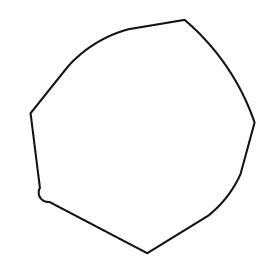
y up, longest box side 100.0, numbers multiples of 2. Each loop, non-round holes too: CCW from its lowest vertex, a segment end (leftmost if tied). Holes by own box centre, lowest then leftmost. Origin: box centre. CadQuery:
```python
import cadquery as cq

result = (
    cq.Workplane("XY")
    .moveTo(2.0, -50.0)
    .lineTo(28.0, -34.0)
    .threePointArc((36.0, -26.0), (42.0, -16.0))
    .lineTo(48.0, 6.0)
    .threePointArc((36.0, 30.0), (18.0, 50.0))
    .lineTo(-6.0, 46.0)
    .threePointArc((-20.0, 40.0), (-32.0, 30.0))
    .lineTo(-48.0, 10.0)
    .lineTo(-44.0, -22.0)
    .threePointArc((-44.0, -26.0), (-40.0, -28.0))
    .close()
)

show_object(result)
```